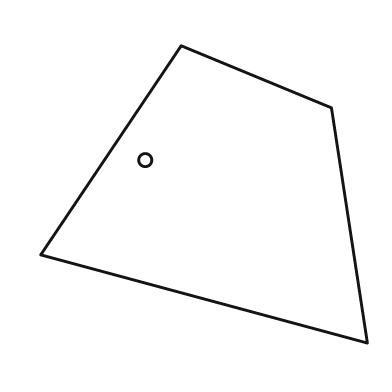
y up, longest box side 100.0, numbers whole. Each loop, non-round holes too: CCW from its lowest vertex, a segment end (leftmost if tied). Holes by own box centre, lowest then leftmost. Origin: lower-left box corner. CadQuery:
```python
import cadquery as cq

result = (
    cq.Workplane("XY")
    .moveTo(100.0, 0.0)
    .lineTo(89.0, 72.0)
    .lineTo(43.0, 91.0)
    .lineTo(0.0, 27.0)
    .close()
    .moveTo(32.0, 56.0)
    .circle(2.0)
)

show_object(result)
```